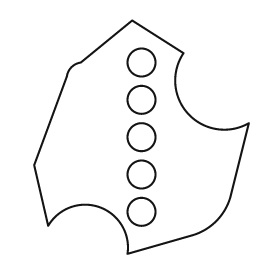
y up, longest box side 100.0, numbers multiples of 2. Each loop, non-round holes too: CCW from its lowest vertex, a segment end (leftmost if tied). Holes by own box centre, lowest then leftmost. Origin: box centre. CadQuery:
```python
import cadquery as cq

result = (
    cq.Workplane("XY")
    .moveTo(-6.0, -50.0)
    .lineTo(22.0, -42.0)
    .threePointArc((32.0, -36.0), (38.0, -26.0))
    .lineTo(46.0, 6.0)
    .threePointArc((20.0, 10.0), (18.0, 36.0))
    .lineTo(-4.0, 50.0)
    .lineTo(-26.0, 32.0)
    .threePointArc((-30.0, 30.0), (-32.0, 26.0))
    .lineTo(-46.0, -12.0)
    .lineTo(-40.0, -38.0)
    .threePointArc((-18.0, -30.0), (-6.0, -50.0))
    .close()
    .moveTo(0.0, -32.0)
    .circle(6.0)
    .moveTo(0.0, -16.0)
    .circle(6.0)
    .moveTo(0.0, 0.0)
    .circle(6.0)
    .moveTo(0.0, 16.0)
    .circle(6.0)
    .moveTo(0.0, 32.0)
    .circle(6.0)
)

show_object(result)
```